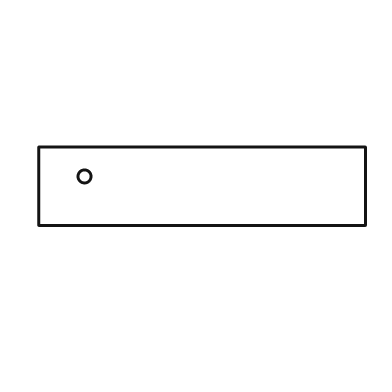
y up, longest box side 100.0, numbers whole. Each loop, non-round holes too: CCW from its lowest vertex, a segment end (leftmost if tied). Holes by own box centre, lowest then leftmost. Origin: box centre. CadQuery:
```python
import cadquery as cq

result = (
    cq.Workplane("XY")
    .moveTo(-50.0, -12.0)
    .lineTo(50.0, -12.0)
    .lineTo(50.0, 12.0)
    .lineTo(-50.0, 12.0)
    .close()
    .moveTo(-36.0, 3.0)
    .circle(2.0)
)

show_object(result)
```